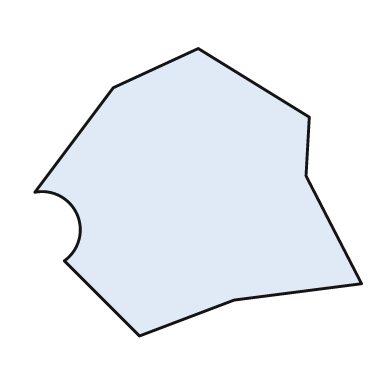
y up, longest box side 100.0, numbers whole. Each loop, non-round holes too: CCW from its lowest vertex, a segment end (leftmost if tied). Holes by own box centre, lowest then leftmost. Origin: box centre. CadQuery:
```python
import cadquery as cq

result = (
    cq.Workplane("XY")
    .moveTo(-18.0, -44.0)
    .lineTo(11.0, -33.0)
    .lineTo(50.0, -28.0)
    .lineTo(33.0, 5.0)
    .lineTo(34.0, 23.0)
    .lineTo(0.0, 44.0)
    .lineTo(-26.0, 32.0)
    .lineTo(-50.0, 0.0)
    .threePointArc((-37.0, -7.0), (-41.0, -21.0))
    .close()
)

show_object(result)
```